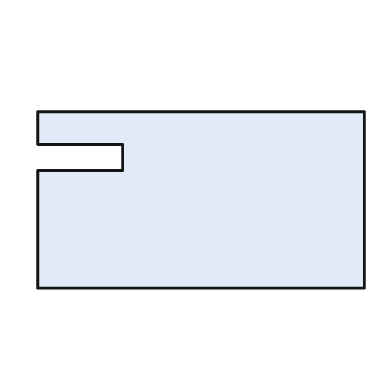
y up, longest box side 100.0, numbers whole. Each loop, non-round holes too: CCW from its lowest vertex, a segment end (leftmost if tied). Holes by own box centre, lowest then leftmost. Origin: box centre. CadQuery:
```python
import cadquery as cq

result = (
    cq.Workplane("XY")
    .moveTo(-50.0, -27.0)
    .lineTo(50.0, -27.0)
    .lineTo(50.0, 27.0)
    .lineTo(-50.0, 27.0)
    .lineTo(-50.0, 17.0)
    .lineTo(-24.0, 17.0)
    .lineTo(-24.0, 9.0)
    .lineTo(-50.0, 9.0)
    .close()
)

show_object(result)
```